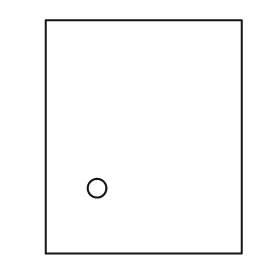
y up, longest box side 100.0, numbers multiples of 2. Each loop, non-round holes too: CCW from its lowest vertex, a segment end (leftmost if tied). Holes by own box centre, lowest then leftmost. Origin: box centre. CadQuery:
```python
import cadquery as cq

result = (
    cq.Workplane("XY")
    .moveTo(-42.0, -50.0)
    .lineTo(42.0, -50.0)
    .lineTo(42.0, 50.0)
    .lineTo(-42.0, 50.0)
    .close()
    .moveTo(-20.0, -22.0)
    .circle(4.0)
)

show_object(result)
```